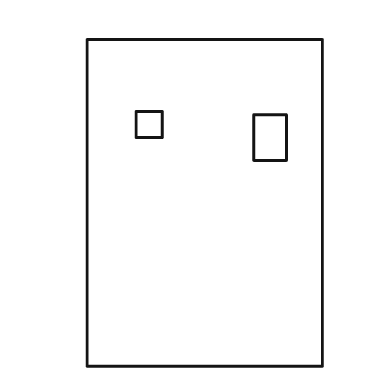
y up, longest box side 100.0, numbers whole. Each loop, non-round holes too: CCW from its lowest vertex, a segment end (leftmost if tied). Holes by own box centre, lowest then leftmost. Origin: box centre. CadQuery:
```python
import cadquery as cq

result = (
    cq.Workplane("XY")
    .moveTo(-36.0, -50.0)
    .lineTo(36.0, -50.0)
    .lineTo(36.0, 50.0)
    .lineTo(-36.0, 50.0)
    .close()
    .moveTo(15.0, 13.0)
    .lineTo(25.0, 13.0)
    .lineTo(25.0, 27.0)
    .lineTo(15.0, 27.0)
    .close()
    .moveTo(-21.0, 20.0)
    .lineTo(-13.0, 20.0)
    .lineTo(-13.0, 28.0)
    .lineTo(-21.0, 28.0)
    .close()
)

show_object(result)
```